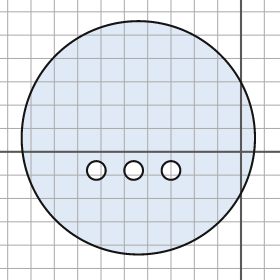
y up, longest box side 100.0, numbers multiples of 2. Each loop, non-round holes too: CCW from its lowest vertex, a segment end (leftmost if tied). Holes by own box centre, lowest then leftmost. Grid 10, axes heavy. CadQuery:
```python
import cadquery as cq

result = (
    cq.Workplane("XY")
    .moveTo(-44.0, 6.0)
    .circle(50.0)
    .moveTo(-62.0, -8.0)
    .circle(4.0)
    .moveTo(-46.0, -8.0)
    .circle(4.0)
    .moveTo(-30.0, -8.0)
    .circle(4.0)
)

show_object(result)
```